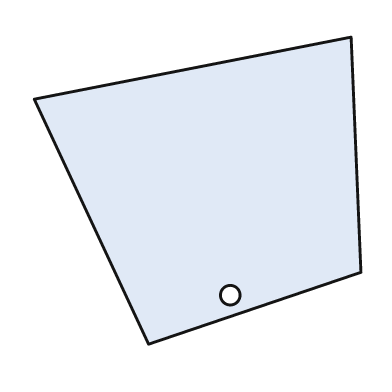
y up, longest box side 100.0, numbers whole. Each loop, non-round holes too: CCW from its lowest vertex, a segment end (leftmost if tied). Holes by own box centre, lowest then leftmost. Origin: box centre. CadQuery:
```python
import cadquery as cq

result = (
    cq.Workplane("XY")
    .moveTo(-15.0, -47.0)
    .lineTo(50.0, -25.0)
    .lineTo(47.0, 47.0)
    .lineTo(-50.0, 28.0)
    .close()
    .moveTo(10.0, -32.0)
    .circle(3.0)
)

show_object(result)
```